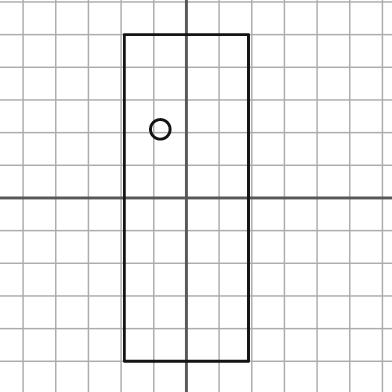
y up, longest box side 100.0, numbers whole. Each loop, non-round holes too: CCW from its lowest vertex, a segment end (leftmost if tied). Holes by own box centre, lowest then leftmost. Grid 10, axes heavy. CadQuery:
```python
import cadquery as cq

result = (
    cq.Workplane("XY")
    .moveTo(-19.0, -50.0)
    .lineTo(19.0, -50.0)
    .lineTo(19.0, 50.0)
    .lineTo(-19.0, 50.0)
    .close()
    .moveTo(-8.0, 21.0)
    .circle(3.0)
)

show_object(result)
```